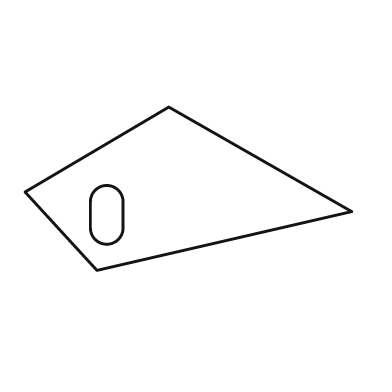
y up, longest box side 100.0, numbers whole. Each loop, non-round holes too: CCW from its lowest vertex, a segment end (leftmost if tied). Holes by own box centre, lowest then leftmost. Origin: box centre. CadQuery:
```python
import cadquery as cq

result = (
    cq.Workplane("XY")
    .moveTo(-28.0, -25.0)
    .lineTo(50.0, -7.0)
    .lineTo(-6.0, 25.0)
    .lineTo(-50.0, -1.0)
    .close()
    .moveTo(-30.0, -12.0)
    .threePointArc((-25.0, -17.0), (-20.0, -12.0))
    .lineTo(-20.0, -4.0)
    .threePointArc((-25.0, 1.0), (-30.0, -4.0))
    .close()
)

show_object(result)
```